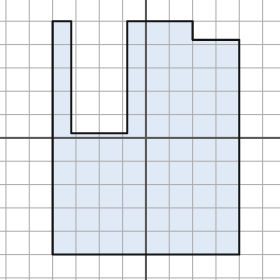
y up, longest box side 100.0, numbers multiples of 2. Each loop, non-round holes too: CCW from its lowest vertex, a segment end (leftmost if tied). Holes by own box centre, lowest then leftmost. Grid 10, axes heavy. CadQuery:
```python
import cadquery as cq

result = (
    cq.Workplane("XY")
    .moveTo(-40.0, -50.0)
    .lineTo(40.0, -50.0)
    .lineTo(40.0, 42.0)
    .lineTo(20.0, 42.0)
    .lineTo(20.0, 50.0)
    .lineTo(-8.0, 50.0)
    .lineTo(-8.0, 2.0)
    .lineTo(-32.0, 2.0)
    .lineTo(-32.0, 50.0)
    .lineTo(-40.0, 50.0)
    .close()
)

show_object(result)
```